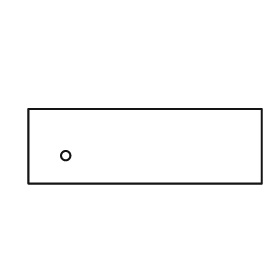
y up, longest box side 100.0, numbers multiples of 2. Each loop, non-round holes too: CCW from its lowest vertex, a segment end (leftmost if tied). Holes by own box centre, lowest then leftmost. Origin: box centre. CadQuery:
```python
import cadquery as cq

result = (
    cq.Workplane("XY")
    .moveTo(-50.0, -16.0)
    .lineTo(50.0, -16.0)
    .lineTo(50.0, 16.0)
    .lineTo(-50.0, 16.0)
    .close()
    .moveTo(-34.0, -4.0)
    .circle(2.0)
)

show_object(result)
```